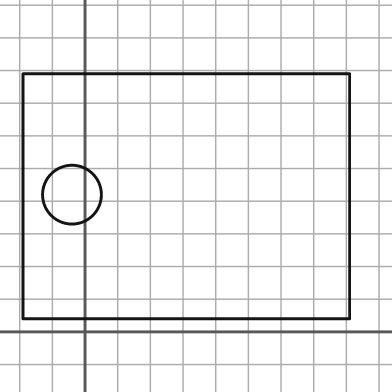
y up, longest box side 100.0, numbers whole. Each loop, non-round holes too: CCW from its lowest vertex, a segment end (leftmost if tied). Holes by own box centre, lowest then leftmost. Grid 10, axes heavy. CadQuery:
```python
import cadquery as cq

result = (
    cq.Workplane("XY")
    .moveTo(-19.0, 4.0)
    .lineTo(81.0, 4.0)
    .lineTo(81.0, 79.0)
    .lineTo(-19.0, 79.0)
    .close()
    .moveTo(-4.0, 42.0)
    .circle(9.0)
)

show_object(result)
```